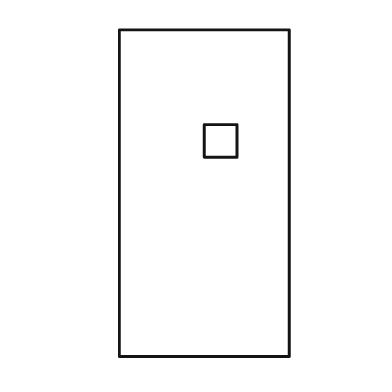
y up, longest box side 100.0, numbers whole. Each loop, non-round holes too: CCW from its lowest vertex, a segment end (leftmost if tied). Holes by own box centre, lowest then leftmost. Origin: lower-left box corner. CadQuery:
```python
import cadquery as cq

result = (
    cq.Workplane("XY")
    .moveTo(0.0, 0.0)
    .lineTo(52.0, 0.0)
    .lineTo(52.0, 100.0)
    .lineTo(0.0, 100.0)
    .close()
    .moveTo(26.0, 61.0)
    .lineTo(36.0, 61.0)
    .lineTo(36.0, 71.0)
    .lineTo(26.0, 71.0)
    .close()
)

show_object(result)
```